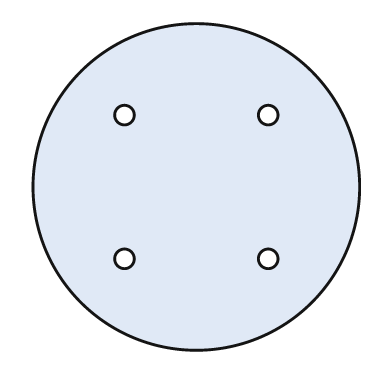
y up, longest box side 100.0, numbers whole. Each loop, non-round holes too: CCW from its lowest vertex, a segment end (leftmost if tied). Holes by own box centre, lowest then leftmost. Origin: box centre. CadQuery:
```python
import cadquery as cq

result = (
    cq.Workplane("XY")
    .moveTo(0.0, 0.0)
    .circle(50.0)
    .moveTo(-22.0, -22.0)
    .circle(3.0)
    .moveTo(22.0, -22.0)
    .circle(3.0)
    .moveTo(-22.0, 22.0)
    .circle(3.0)
    .moveTo(22.0, 22.0)
    .circle(3.0)
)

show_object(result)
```